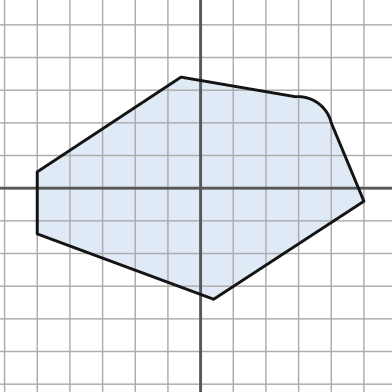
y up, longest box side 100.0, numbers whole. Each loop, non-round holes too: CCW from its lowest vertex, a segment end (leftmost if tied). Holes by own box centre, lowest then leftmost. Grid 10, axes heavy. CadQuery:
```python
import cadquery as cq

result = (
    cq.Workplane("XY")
    .moveTo(4.0, -34.0)
    .lineTo(50.0, -4.0)
    .lineTo(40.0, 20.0)
    .threePointArc((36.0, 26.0), (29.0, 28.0))
    .lineTo(-6.0, 34.0)
    .lineTo(-50.0, 5.0)
    .lineTo(-50.0, -14.0)
    .close()
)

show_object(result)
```